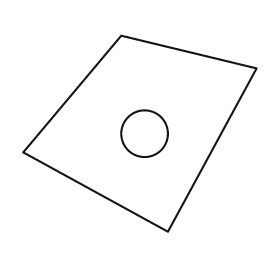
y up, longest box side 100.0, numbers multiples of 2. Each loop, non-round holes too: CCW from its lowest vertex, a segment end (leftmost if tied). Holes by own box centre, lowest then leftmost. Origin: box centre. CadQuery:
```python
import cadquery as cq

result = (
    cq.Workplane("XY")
    .moveTo(12.0, -42.0)
    .lineTo(50.0, 28.0)
    .lineTo(-8.0, 42.0)
    .lineTo(-50.0, -8.0)
    .close()
    .moveTo(2.0, 0.0)
    .circle(10.0)
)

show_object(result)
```